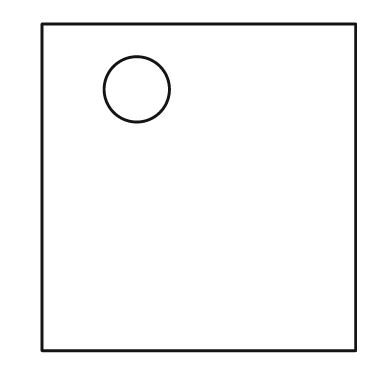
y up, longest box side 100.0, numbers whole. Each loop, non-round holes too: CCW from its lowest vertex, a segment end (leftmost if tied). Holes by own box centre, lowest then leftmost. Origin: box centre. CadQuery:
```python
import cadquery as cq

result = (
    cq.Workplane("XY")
    .moveTo(-48.0, -50.0)
    .lineTo(48.0, -50.0)
    .lineTo(48.0, 50.0)
    .lineTo(-48.0, 50.0)
    .close()
    .moveTo(-19.0, 30.0)
    .circle(10.0)
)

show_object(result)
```